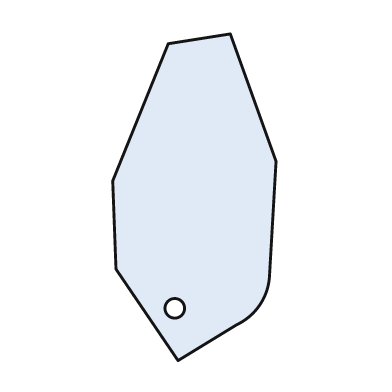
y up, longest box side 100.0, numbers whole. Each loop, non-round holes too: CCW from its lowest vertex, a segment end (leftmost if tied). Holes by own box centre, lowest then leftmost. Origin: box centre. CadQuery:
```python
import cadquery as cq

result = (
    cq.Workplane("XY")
    .moveTo(-5.0, -50.0)
    .lineTo(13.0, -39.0)
    .threePointArc((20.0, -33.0), (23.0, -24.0))
    .lineTo(25.0, 11.0)
    .lineTo(11.0, 50.0)
    .lineTo(-8.0, 47.0)
    .lineTo(-25.0, 5.0)
    .lineTo(-24.0, -22.0)
    .close()
    .moveTo(-6.0, -34.0)
    .circle(3.0)
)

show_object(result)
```